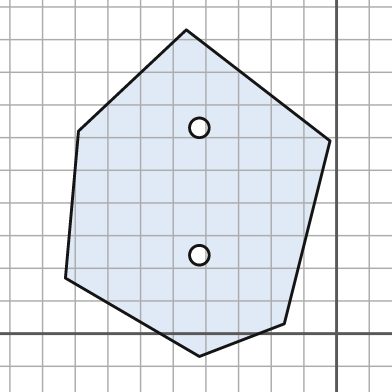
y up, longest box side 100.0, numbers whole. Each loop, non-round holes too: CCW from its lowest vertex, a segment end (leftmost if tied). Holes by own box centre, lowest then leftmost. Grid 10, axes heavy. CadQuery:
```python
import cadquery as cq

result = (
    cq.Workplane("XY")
    .moveTo(-42.0, -7.0)
    .lineTo(-16.0, 3.0)
    .lineTo(-2.0, 59.0)
    .lineTo(-46.0, 93.0)
    .lineTo(-79.0, 62.0)
    .lineTo(-83.0, 17.0)
    .close()
    .moveTo(-42.0, 24.0)
    .circle(3.0)
    .moveTo(-42.0, 63.0)
    .circle(3.0)
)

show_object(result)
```